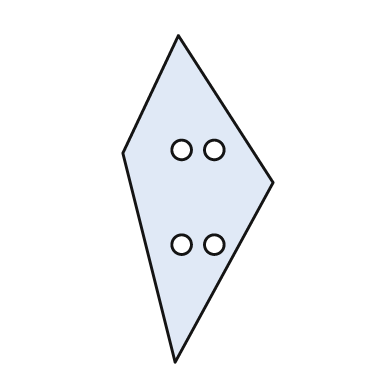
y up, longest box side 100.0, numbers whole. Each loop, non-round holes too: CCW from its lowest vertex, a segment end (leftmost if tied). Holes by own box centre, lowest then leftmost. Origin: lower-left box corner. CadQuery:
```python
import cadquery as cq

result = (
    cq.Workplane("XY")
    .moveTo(16.0, 0.0)
    .lineTo(46.0, 55.0)
    .lineTo(17.0, 100.0)
    .lineTo(0.0, 64.0)
    .close()
    .moveTo(18.0, 36.0)
    .circle(3.0)
    .moveTo(28.0, 36.0)
    .circle(3.0)
    .moveTo(18.0, 65.0)
    .circle(3.0)
    .moveTo(28.0, 65.0)
    .circle(3.0)
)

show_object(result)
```